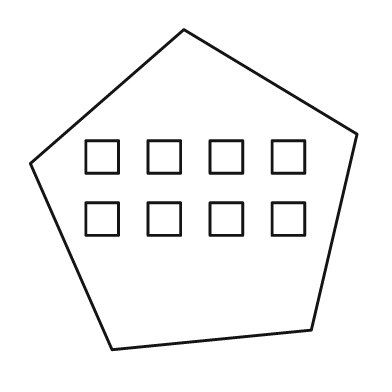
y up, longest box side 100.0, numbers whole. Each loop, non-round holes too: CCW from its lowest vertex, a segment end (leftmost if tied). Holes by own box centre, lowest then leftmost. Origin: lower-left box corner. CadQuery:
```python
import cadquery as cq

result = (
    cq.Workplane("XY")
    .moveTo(25.0, 0.0)
    .lineTo(86.0, 6.0)
    .lineTo(100.0, 66.0)
    .lineTo(47.0, 98.0)
    .lineTo(0.0, 57.0)
    .close()
    .moveTo(17.0, 35.0)
    .lineTo(27.0, 35.0)
    .lineTo(27.0, 45.0)
    .lineTo(17.0, 45.0)
    .close()
    .moveTo(36.0, 35.0)
    .lineTo(46.0, 35.0)
    .lineTo(46.0, 45.0)
    .lineTo(36.0, 45.0)
    .close()
    .moveTo(55.0, 35.0)
    .lineTo(65.0, 35.0)
    .lineTo(65.0, 45.0)
    .lineTo(55.0, 45.0)
    .close()
    .moveTo(74.0, 35.0)
    .lineTo(84.0, 35.0)
    .lineTo(84.0, 45.0)
    .lineTo(74.0, 45.0)
    .close()
    .moveTo(17.0, 54.0)
    .lineTo(27.0, 54.0)
    .lineTo(27.0, 64.0)
    .lineTo(17.0, 64.0)
    .close()
    .moveTo(36.0, 54.0)
    .lineTo(46.0, 54.0)
    .lineTo(46.0, 64.0)
    .lineTo(36.0, 64.0)
    .close()
    .moveTo(55.0, 54.0)
    .lineTo(65.0, 54.0)
    .lineTo(65.0, 64.0)
    .lineTo(55.0, 64.0)
    .close()
    .moveTo(74.0, 54.0)
    .lineTo(84.0, 54.0)
    .lineTo(84.0, 64.0)
    .lineTo(74.0, 64.0)
    .close()
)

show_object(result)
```